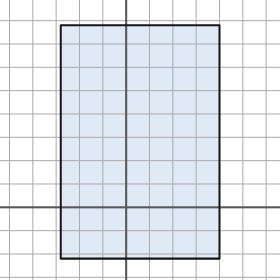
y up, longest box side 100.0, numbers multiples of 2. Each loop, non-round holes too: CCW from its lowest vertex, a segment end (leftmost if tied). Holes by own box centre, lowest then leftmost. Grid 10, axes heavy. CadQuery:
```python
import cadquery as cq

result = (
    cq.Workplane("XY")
    .moveTo(-28.0, -22.0)
    .lineTo(40.0, -22.0)
    .lineTo(40.0, 78.0)
    .lineTo(-28.0, 78.0)
    .close()
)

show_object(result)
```